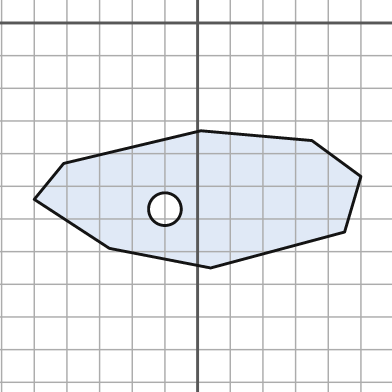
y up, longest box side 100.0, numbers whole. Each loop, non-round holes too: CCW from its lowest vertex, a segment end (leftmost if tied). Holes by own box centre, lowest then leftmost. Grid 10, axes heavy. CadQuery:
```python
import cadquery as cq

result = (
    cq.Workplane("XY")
    .moveTo(4.0, -75.0)
    .lineTo(45.0, -64.0)
    .lineTo(50.0, -47.0)
    .lineTo(35.0, -36.0)
    .lineTo(1.0, -33.0)
    .lineTo(-41.0, -43.0)
    .lineTo(-50.0, -54.0)
    .lineTo(-27.0, -69.0)
    .close()
    .moveTo(-10.0, -57.0)
    .circle(5.0)
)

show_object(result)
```